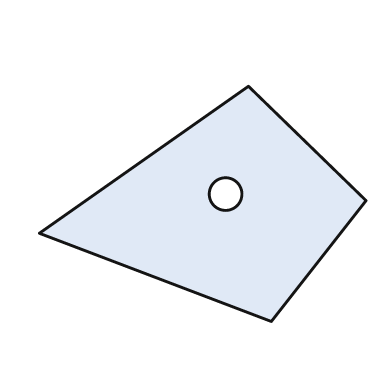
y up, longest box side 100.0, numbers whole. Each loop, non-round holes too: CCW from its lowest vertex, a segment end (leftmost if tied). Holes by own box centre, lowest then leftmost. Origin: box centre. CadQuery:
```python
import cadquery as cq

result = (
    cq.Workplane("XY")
    .moveTo(21.0, -36.0)
    .lineTo(50.0, 1.0)
    .lineTo(14.0, 36.0)
    .lineTo(-50.0, -9.0)
    .close()
    .moveTo(7.0, 3.0)
    .circle(5.0)
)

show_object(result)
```